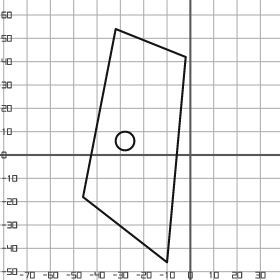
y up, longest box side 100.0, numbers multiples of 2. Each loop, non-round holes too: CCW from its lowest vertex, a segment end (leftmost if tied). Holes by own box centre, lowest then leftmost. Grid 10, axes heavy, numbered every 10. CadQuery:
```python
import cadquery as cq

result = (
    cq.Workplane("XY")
    .moveTo(-10.0, -46.0)
    .lineTo(-2.0, 42.0)
    .lineTo(-32.0, 54.0)
    .lineTo(-46.0, -18.0)
    .close()
    .moveTo(-28.0, 6.0)
    .circle(4.0)
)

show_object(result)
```